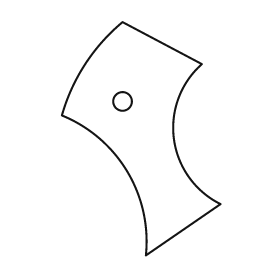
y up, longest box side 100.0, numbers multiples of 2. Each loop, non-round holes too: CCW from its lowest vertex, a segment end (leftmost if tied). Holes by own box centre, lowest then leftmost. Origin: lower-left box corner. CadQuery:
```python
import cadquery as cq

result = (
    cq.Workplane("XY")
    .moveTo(36.0, 0.0)
    .lineTo(68.0, 22.0)
    .threePointArc((48.0, 50.0), (60.0, 82.0))
    .lineTo(26.0, 100.0)
    .threePointArc((10.0, 82.0), (0.0, 60.0))
    .threePointArc((28.0, 36.0), (36.0, 0.0))
    .close()
    .moveTo(26.0, 66.0)
    .circle(4.0)
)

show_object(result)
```